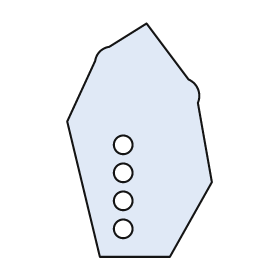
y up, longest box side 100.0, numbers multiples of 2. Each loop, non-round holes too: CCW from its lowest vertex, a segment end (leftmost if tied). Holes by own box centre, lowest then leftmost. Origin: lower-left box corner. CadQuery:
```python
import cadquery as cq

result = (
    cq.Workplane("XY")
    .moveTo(14.0, 0.0)
    .lineTo(44.0, 0.0)
    .lineTo(62.0, 32.0)
    .lineTo(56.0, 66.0)
    .threePointArc((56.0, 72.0), (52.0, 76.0))
    .lineTo(34.0, 100.0)
    .lineTo(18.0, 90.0)
    .threePointArc((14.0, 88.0), (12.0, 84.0))
    .lineTo(0.0, 58.0)
    .close()
    .moveTo(24.0, 12.0)
    .circle(4.0)
    .moveTo(24.0, 24.0)
    .circle(4.0)
    .moveTo(24.0, 36.0)
    .circle(4.0)
    .moveTo(24.0, 48.0)
    .circle(4.0)
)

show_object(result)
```